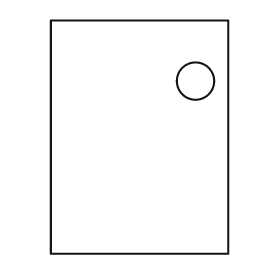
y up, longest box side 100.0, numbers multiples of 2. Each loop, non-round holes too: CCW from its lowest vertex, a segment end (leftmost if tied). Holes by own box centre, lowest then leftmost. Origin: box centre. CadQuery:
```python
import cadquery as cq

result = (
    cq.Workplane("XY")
    .moveTo(-38.0, -50.0)
    .lineTo(38.0, -50.0)
    .lineTo(38.0, 50.0)
    .lineTo(-38.0, 50.0)
    .close()
    .moveTo(24.0, 24.0)
    .circle(8.0)
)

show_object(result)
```